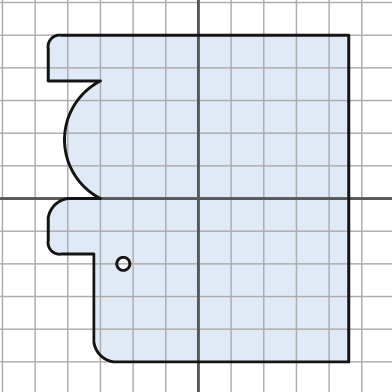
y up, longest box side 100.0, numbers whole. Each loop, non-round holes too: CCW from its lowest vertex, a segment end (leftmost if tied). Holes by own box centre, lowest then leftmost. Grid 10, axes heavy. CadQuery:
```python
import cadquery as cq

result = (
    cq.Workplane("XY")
    .moveTo(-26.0, -50.0)
    .lineTo(46.0, -50.0)
    .lineTo(46.0, 50.0)
    .lineTo(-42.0, 50.0)
    .threePointArc((-45.0, 49.0), (-46.0, 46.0))
    .lineTo(-46.0, 36.0)
    .lineTo(-30.0, 36.0)
    .threePointArc((-41.0, 18.0), (-30.0, 0.0))
    .lineTo(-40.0, 0.0)
    .threePointArc((-44.0, -2.0), (-46.0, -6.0))
    .lineTo(-46.0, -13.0)
    .threePointArc((-45.0, -16.0), (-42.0, -17.0))
    .lineTo(-32.0, -17.0)
    .lineTo(-32.0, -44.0)
    .threePointArc((-30.0, -48.0), (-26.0, -50.0))
    .close()
    .moveTo(-23.0, -20.0)
    .circle(2.0)
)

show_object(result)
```